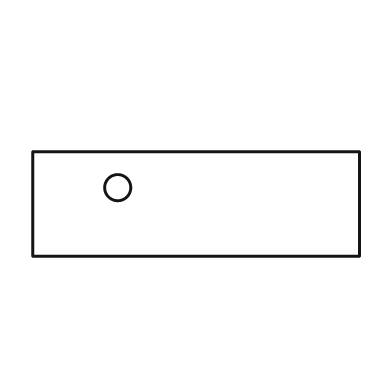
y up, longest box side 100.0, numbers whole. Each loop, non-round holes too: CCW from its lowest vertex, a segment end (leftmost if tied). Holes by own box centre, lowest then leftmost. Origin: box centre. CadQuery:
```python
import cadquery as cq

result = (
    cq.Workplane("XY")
    .moveTo(-50.0, -16.0)
    .lineTo(50.0, -16.0)
    .lineTo(50.0, 16.0)
    .lineTo(-50.0, 16.0)
    .close()
    .moveTo(-24.0, 5.0)
    .circle(4.0)
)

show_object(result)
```